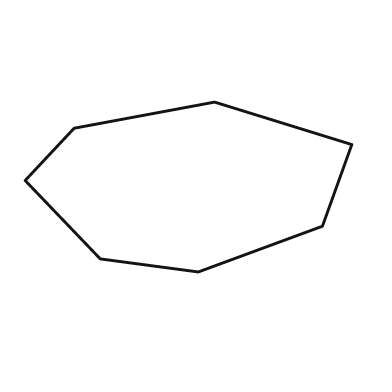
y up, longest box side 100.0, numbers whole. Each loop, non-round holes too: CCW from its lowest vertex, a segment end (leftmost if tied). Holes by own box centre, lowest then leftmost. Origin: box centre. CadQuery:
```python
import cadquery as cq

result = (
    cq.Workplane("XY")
    .moveTo(3.0, -26.0)
    .lineTo(41.0, -12.0)
    .lineTo(50.0, 13.0)
    .lineTo(8.0, 26.0)
    .lineTo(-35.0, 18.0)
    .lineTo(-50.0, 2.0)
    .lineTo(-27.0, -22.0)
    .close()
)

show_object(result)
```